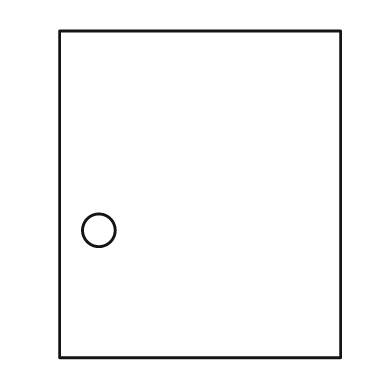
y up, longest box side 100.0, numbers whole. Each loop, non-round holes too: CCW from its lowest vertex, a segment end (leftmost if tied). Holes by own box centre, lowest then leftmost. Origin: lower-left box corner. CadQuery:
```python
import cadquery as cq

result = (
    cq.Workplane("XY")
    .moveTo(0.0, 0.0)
    .lineTo(86.0, 0.0)
    .lineTo(86.0, 100.0)
    .lineTo(0.0, 100.0)
    .close()
    .moveTo(12.0, 39.0)
    .circle(5.0)
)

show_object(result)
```